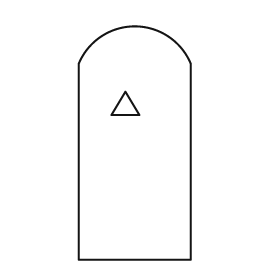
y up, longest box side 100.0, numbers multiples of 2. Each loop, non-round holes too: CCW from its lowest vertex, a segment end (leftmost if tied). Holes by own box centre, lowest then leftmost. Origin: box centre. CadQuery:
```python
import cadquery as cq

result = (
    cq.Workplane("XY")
    .moveTo(-24.0, -50.0)
    .lineTo(24.0, -50.0)
    .lineTo(24.0, 34.0)
    .threePointArc((0.0, 50.0), (-24.0, 34.0))
    .close()
    .moveTo(-10.0, 12.0)
    .lineTo(2.0, 12.0)
    .lineTo(-4.0, 22.0)
    .close()
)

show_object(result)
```